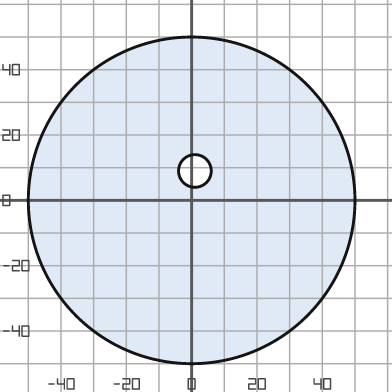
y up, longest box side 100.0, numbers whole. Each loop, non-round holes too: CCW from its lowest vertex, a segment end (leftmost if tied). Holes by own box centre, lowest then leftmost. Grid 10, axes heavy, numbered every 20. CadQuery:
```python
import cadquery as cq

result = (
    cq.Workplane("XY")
    .moveTo(0.0, 0.0)
    .circle(50.0)
    .moveTo(1.0, 9.0)
    .circle(5.0)
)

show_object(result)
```